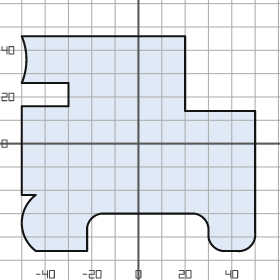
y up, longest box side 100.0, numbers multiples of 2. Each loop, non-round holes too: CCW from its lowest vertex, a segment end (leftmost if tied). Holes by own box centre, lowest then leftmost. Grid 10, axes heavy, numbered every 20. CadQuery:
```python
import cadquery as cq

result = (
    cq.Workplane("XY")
    .moveTo(-44.0, -46.0)
    .lineTo(-22.0, -46.0)
    .lineTo(-22.0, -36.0)
    .threePointArc((-20.0, -32.0), (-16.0, -30.0))
    .lineTo(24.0, -30.0)
    .threePointArc((28.0, -32.0), (30.0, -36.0))
    .lineTo(30.0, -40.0)
    .threePointArc((32.0, -44.0), (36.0, -46.0))
    .lineTo(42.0, -46.0)
    .threePointArc((48.0, -44.0), (50.0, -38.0))
    .lineTo(50.0, 14.0)
    .lineTo(20.0, 14.0)
    .lineTo(20.0, 46.0)
    .lineTo(-50.0, 46.0)
    .threePointArc((-48.0, 36.0), (-50.0, 26.0))
    .lineTo(-30.0, 26.0)
    .lineTo(-30.0, 16.0)
    .lineTo(-50.0, 16.0)
    .lineTo(-50.0, -22.0)
    .lineTo(-44.0, -22.0)
    .threePointArc((-50.0, -34.0), (-44.0, -46.0))
    .close()
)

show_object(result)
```